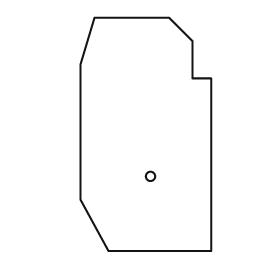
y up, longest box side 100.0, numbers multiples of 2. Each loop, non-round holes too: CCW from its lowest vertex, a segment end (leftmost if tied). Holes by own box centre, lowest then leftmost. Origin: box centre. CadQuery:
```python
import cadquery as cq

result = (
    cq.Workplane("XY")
    .moveTo(-16.0, -50.0)
    .lineTo(28.0, -50.0)
    .lineTo(28.0, 24.0)
    .lineTo(20.0, 24.0)
    .lineTo(20.0, 40.0)
    .lineTo(10.0, 50.0)
    .lineTo(-22.0, 50.0)
    .lineTo(-28.0, 30.0)
    .lineTo(-28.0, -28.0)
    .close()
    .moveTo(2.0, -18.0)
    .circle(2.0)
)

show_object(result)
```